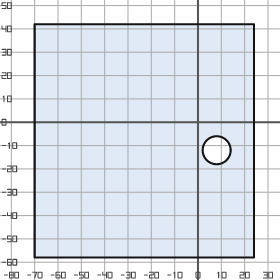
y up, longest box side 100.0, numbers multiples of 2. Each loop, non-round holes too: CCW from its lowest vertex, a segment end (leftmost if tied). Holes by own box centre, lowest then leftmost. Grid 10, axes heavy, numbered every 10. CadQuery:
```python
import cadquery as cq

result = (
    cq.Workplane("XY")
    .moveTo(-70.0, -58.0)
    .lineTo(24.0, -58.0)
    .lineTo(24.0, 42.0)
    .lineTo(-70.0, 42.0)
    .close()
    .moveTo(8.0, -12.0)
    .circle(6.0)
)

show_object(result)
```